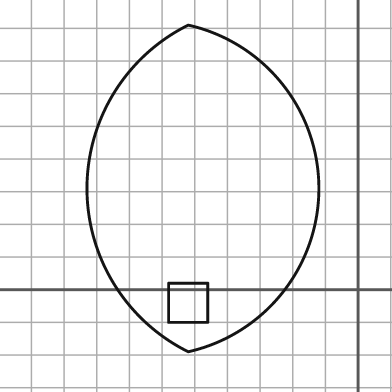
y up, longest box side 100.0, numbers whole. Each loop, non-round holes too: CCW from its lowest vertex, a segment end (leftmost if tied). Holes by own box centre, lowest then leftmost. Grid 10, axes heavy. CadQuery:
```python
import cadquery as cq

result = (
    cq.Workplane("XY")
    .moveTo(-52.0, -19.0)
    .threePointArc((-12.0, 31.0), (-52.0, 81.0))
    .threePointArc((-83.0, 31.0), (-52.0, -19.0))
    .close()
    .moveTo(-58.0, -10.0)
    .lineTo(-46.0, -10.0)
    .lineTo(-46.0, 2.0)
    .lineTo(-58.0, 2.0)
    .close()
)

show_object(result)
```